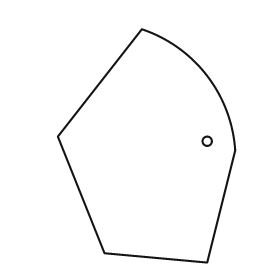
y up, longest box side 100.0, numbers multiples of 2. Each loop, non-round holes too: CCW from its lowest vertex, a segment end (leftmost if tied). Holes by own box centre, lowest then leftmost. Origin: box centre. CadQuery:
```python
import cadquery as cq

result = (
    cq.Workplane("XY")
    .moveTo(26.0, -50.0)
    .lineTo(38.0, -2.0)
    .threePointArc((26.0, 30.0), (-2.0, 50.0))
    .lineTo(-38.0, 4.0)
    .lineTo(-18.0, -46.0)
    .close()
    .moveTo(26.0, 2.0)
    .circle(2.0)
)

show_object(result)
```